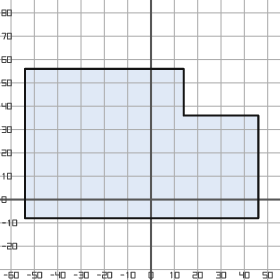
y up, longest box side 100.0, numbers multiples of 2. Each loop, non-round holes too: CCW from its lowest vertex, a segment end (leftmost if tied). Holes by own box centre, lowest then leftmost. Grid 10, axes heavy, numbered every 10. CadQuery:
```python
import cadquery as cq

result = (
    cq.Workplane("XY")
    .moveTo(-54.0, -8.0)
    .lineTo(46.0, -8.0)
    .lineTo(46.0, 36.0)
    .lineTo(14.0, 36.0)
    .lineTo(14.0, 56.0)
    .lineTo(-54.0, 56.0)
    .close()
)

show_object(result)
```